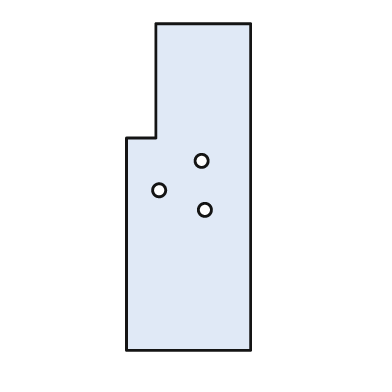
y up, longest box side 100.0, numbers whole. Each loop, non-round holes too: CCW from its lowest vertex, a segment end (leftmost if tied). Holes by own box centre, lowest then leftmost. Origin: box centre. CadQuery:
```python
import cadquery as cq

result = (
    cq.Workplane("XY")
    .moveTo(-19.0, -50.0)
    .lineTo(19.0, -50.0)
    .lineTo(19.0, 50.0)
    .lineTo(-10.0, 50.0)
    .lineTo(-10.0, 15.0)
    .lineTo(-19.0, 15.0)
    .close()
    .moveTo(5.0, -7.0)
    .circle(2.0)
    .moveTo(-9.0, -1.0)
    .circle(2.0)
    .moveTo(4.0, 8.0)
    .circle(2.0)
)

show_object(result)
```